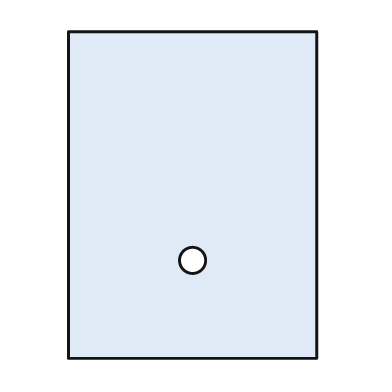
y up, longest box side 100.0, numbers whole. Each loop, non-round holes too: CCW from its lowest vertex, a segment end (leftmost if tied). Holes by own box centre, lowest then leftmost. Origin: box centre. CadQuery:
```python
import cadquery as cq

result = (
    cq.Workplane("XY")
    .moveTo(-38.0, -50.0)
    .lineTo(38.0, -50.0)
    .lineTo(38.0, 50.0)
    .lineTo(-38.0, 50.0)
    .close()
    .moveTo(0.0, -20.0)
    .circle(4.0)
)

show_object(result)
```